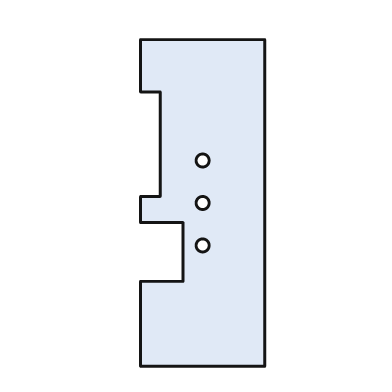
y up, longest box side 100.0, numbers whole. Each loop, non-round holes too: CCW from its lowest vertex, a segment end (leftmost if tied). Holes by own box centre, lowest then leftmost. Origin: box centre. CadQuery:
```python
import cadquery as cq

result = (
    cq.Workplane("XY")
    .moveTo(-19.0, -50.0)
    .lineTo(19.0, -50.0)
    .lineTo(19.0, 50.0)
    .lineTo(-19.0, 50.0)
    .lineTo(-19.0, 34.0)
    .lineTo(-13.0, 34.0)
    .lineTo(-13.0, 2.0)
    .lineTo(-19.0, 2.0)
    .lineTo(-19.0, -6.0)
    .lineTo(-6.0, -6.0)
    .lineTo(-6.0, -24.0)
    .lineTo(-19.0, -24.0)
    .close()
    .moveTo(0.0, -13.0)
    .circle(2.0)
    .moveTo(0.0, 0.0)
    .circle(2.0)
    .moveTo(0.0, 13.0)
    .circle(2.0)
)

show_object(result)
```